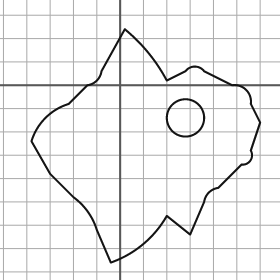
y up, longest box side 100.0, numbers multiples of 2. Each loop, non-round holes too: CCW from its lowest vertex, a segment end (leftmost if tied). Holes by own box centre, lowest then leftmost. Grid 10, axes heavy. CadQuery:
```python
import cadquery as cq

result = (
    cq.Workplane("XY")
    .moveTo(-4.0, -76.0)
    .threePointArc((10.0, -68.0), (20.0, -56.0))
    .lineTo(30.0, -64.0)
    .lineTo(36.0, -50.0)
    .threePointArc((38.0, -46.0), (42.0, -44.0))
    .lineTo(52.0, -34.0)
    .threePointArc((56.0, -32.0), (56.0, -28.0))
    .lineTo(60.0, -16.0)
    .lineTo(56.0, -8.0)
    .threePointArc((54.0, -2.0), (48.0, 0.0))
    .lineTo(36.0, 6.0)
    .threePointArc((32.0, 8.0), (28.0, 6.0))
    .lineTo(20.0, 2.0)
    .threePointArc((12.0, 14.0), (2.0, 24.0))
    .lineTo(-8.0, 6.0)
    .threePointArc((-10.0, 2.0), (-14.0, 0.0))
    .lineTo(-22.0, -8.0)
    .threePointArc((-32.0, -14.0), (-38.0, -24.0))
    .lineTo(-30.0, -38.0)
    .lineTo(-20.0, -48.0)
    .threePointArc((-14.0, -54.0), (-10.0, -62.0))
    .close()
    .moveTo(28.0, -14.0)
    .circle(8.0)
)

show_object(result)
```